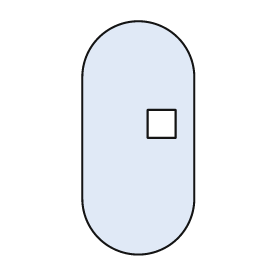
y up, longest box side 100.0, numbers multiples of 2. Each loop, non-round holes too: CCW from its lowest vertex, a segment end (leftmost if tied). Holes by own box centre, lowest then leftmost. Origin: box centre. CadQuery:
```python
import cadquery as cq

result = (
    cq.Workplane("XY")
    .moveTo(-24.0, -26.0)
    .threePointArc((0.0, -50.0), (24.0, -26.0))
    .lineTo(24.0, 26.0)
    .threePointArc((0.0, 50.0), (-24.0, 26.0))
    .close()
    .moveTo(4.0, 0.0)
    .lineTo(16.0, 0.0)
    .lineTo(16.0, 12.0)
    .lineTo(4.0, 12.0)
    .close()
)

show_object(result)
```